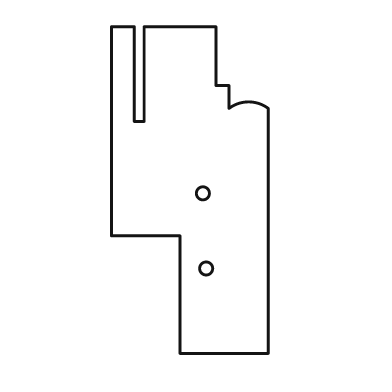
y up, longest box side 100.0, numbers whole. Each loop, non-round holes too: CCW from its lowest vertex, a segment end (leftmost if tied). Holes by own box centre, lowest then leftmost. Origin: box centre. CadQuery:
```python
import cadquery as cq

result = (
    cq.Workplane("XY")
    .moveTo(-3.0, -50.0)
    .lineTo(24.0, -50.0)
    .lineTo(24.0, 25.0)
    .threePointArc((18.0, 27.0), (12.0, 25.0))
    .lineTo(12.0, 32.0)
    .lineTo(8.0, 32.0)
    .lineTo(8.0, 50.0)
    .lineTo(-14.0, 50.0)
    .lineTo(-14.0, 21.0)
    .lineTo(-17.0, 21.0)
    .lineTo(-17.0, 50.0)
    .lineTo(-24.0, 50.0)
    .lineTo(-24.0, -14.0)
    .lineTo(-3.0, -14.0)
    .close()
    .moveTo(5.0, -24.0)
    .circle(2.0)
    .moveTo(4.0, -1.0)
    .circle(2.0)
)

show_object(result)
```